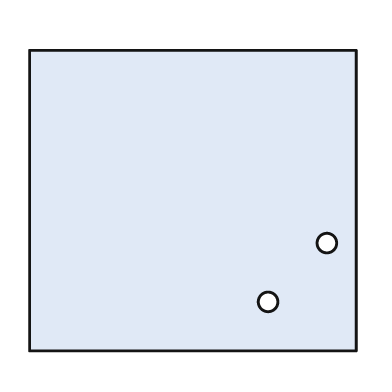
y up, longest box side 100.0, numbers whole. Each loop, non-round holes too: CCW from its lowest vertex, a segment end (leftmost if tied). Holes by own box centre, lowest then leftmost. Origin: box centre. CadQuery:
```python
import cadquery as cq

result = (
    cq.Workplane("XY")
    .moveTo(-50.0, -46.0)
    .lineTo(50.0, -46.0)
    .lineTo(50.0, 46.0)
    .lineTo(-50.0, 46.0)
    .close()
    .moveTo(23.0, -31.0)
    .circle(3.0)
    .moveTo(41.0, -13.0)
    .circle(3.0)
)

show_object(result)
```